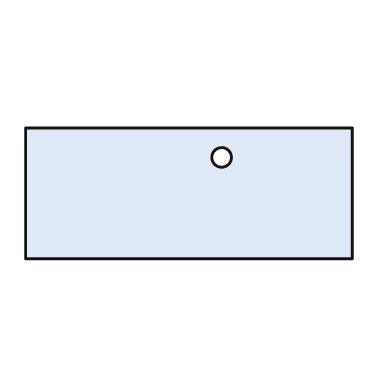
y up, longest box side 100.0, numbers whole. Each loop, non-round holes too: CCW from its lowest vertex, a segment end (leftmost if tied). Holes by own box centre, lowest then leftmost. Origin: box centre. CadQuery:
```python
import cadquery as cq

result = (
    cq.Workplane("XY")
    .moveTo(-50.0, -20.0)
    .lineTo(50.0, -20.0)
    .lineTo(50.0, 20.0)
    .lineTo(-50.0, 20.0)
    .close()
    .moveTo(10.0, 11.0)
    .circle(3.0)
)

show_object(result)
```